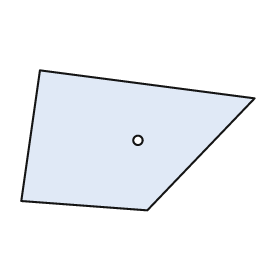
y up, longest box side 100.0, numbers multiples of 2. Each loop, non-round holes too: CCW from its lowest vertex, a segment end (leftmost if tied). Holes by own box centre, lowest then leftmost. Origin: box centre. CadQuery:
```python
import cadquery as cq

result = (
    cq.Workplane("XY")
    .moveTo(4.0, -30.0)
    .lineTo(50.0, 18.0)
    .lineTo(-42.0, 30.0)
    .lineTo(-50.0, -26.0)
    .close()
    .moveTo(0.0, 0.0)
    .circle(2.0)
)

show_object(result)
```